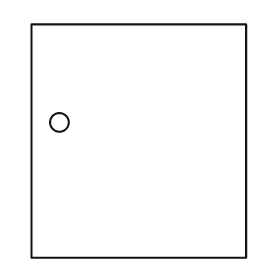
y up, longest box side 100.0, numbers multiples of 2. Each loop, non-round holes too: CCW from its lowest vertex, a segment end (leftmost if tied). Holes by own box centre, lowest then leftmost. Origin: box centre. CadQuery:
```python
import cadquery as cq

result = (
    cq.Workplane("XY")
    .moveTo(-46.0, -50.0)
    .lineTo(46.0, -50.0)
    .lineTo(46.0, 50.0)
    .lineTo(-46.0, 50.0)
    .close()
    .moveTo(-34.0, 8.0)
    .circle(4.0)
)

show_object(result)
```